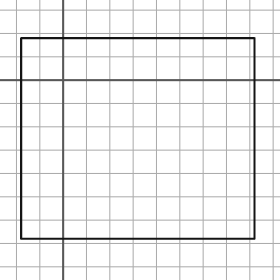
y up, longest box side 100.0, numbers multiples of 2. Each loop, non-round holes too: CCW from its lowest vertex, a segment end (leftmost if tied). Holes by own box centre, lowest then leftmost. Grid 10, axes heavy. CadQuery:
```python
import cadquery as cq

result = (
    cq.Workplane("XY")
    .moveTo(-18.0, -68.0)
    .lineTo(82.0, -68.0)
    .lineTo(82.0, 18.0)
    .lineTo(-18.0, 18.0)
    .close()
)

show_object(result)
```